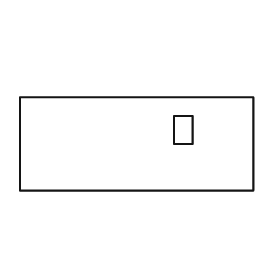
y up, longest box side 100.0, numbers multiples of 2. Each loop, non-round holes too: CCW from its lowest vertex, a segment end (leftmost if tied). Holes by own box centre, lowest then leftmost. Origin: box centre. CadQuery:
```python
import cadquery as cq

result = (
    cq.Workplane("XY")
    .moveTo(-50.0, -20.0)
    .lineTo(50.0, -20.0)
    .lineTo(50.0, 20.0)
    .lineTo(-50.0, 20.0)
    .close()
    .moveTo(16.0, 0.0)
    .lineTo(24.0, 0.0)
    .lineTo(24.0, 12.0)
    .lineTo(16.0, 12.0)
    .close()
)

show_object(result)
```